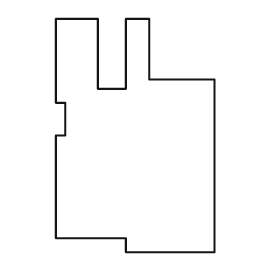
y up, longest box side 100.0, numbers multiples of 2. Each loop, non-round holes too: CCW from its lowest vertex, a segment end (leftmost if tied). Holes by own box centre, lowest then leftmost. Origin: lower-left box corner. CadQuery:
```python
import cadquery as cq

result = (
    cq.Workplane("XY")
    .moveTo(30.0, 0.0)
    .lineTo(68.0, 0.0)
    .lineTo(68.0, 74.0)
    .lineTo(40.0, 74.0)
    .lineTo(40.0, 100.0)
    .lineTo(30.0, 100.0)
    .lineTo(30.0, 70.0)
    .lineTo(18.0, 70.0)
    .lineTo(18.0, 100.0)
    .lineTo(0.0, 100.0)
    .lineTo(0.0, 64.0)
    .lineTo(4.0, 64.0)
    .lineTo(4.0, 50.0)
    .lineTo(0.0, 50.0)
    .lineTo(0.0, 6.0)
    .lineTo(30.0, 6.0)
    .close()
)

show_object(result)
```